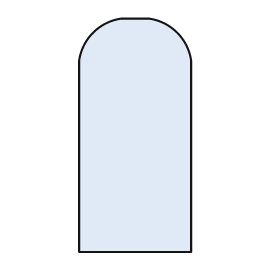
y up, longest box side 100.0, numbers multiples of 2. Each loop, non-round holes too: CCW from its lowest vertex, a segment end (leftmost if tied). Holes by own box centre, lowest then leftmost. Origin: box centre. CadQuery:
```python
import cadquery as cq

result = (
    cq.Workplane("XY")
    .moveTo(-24.0, -50.0)
    .lineTo(24.0, -50.0)
    .lineTo(24.0, 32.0)
    .threePointArc((18.0, 44.0), (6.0, 50.0))
    .lineTo(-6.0, 50.0)
    .threePointArc((-18.0, 44.0), (-24.0, 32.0))
    .close()
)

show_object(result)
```